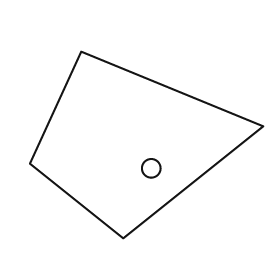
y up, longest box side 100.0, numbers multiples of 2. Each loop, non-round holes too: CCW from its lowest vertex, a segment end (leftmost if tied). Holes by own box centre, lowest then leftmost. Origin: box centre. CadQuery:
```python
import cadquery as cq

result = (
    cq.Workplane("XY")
    .moveTo(-10.0, -40.0)
    .lineTo(50.0, 8.0)
    .lineTo(-28.0, 40.0)
    .lineTo(-50.0, -8.0)
    .close()
    .moveTo(2.0, -10.0)
    .circle(4.0)
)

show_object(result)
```